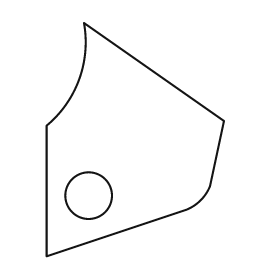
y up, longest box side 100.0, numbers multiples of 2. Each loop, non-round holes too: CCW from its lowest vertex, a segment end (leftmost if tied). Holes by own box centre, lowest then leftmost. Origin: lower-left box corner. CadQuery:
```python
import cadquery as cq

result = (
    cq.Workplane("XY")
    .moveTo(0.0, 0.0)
    .lineTo(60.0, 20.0)
    .threePointArc((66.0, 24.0), (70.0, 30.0))
    .lineTo(76.0, 58.0)
    .lineTo(16.0, 100.0)
    .threePointArc((14.0, 76.0), (0.0, 56.0))
    .close()
    .moveTo(18.0, 26.0)
    .circle(10.0)
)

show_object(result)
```